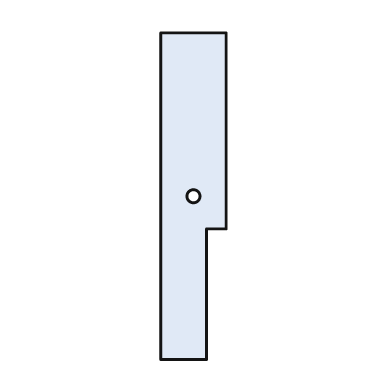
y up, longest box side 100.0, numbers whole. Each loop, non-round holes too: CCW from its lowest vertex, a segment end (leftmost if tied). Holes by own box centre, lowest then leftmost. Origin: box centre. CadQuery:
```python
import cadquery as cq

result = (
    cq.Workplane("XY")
    .moveTo(-10.0, -50.0)
    .lineTo(4.0, -50.0)
    .lineTo(4.0, -10.0)
    .lineTo(10.0, -10.0)
    .lineTo(10.0, 50.0)
    .lineTo(-10.0, 50.0)
    .close()
    .moveTo(0.0, 0.0)
    .circle(2.0)
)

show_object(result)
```